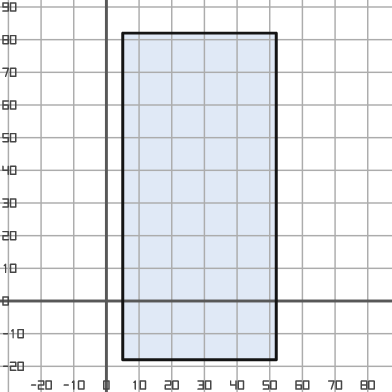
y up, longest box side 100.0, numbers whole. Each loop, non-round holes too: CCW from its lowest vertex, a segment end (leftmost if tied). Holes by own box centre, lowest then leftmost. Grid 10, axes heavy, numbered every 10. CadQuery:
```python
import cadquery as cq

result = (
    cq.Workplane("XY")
    .moveTo(5.0, -18.0)
    .lineTo(52.0, -18.0)
    .lineTo(52.0, 82.0)
    .lineTo(5.0, 82.0)
    .close()
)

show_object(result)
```